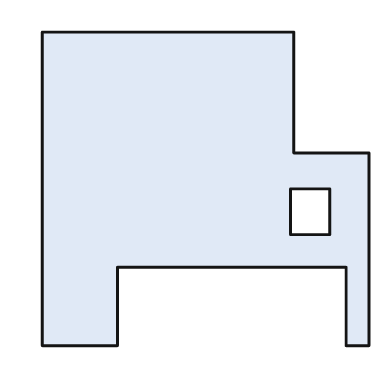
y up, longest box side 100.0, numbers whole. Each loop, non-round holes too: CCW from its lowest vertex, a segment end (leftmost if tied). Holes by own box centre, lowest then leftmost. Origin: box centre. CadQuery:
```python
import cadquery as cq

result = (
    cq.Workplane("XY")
    .moveTo(-50.0, -48.0)
    .lineTo(-27.0, -48.0)
    .lineTo(-27.0, -24.0)
    .lineTo(43.0, -24.0)
    .lineTo(43.0, -48.0)
    .lineTo(50.0, -48.0)
    .lineTo(50.0, 11.0)
    .lineTo(27.0, 11.0)
    .lineTo(27.0, 48.0)
    .lineTo(-50.0, 48.0)
    .close()
    .moveTo(26.0, -14.0)
    .lineTo(38.0, -14.0)
    .lineTo(38.0, 0.0)
    .lineTo(26.0, 0.0)
    .close()
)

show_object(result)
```